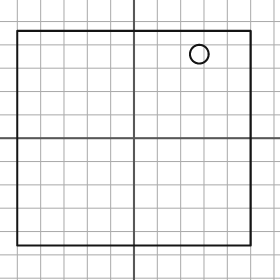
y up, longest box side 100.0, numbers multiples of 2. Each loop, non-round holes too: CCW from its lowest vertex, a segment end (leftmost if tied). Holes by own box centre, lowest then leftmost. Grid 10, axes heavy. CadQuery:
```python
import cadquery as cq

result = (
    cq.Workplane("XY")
    .moveTo(-50.0, -46.0)
    .lineTo(50.0, -46.0)
    .lineTo(50.0, 46.0)
    .lineTo(-50.0, 46.0)
    .close()
    .moveTo(28.0, 36.0)
    .circle(4.0)
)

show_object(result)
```